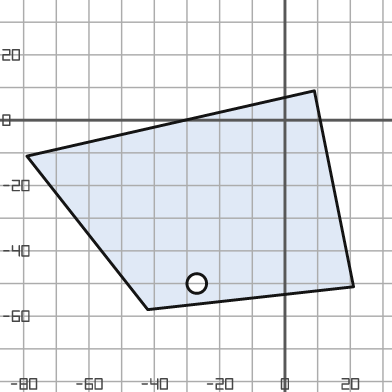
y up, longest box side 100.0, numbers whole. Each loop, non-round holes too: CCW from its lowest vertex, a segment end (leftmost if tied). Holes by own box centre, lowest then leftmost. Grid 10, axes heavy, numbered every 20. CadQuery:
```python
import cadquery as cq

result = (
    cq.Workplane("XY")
    .moveTo(-42.0, -58.0)
    .lineTo(21.0, -51.0)
    .lineTo(9.0, 9.0)
    .lineTo(-79.0, -11.0)
    .close()
    .moveTo(-27.0, -50.0)
    .circle(3.0)
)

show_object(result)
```